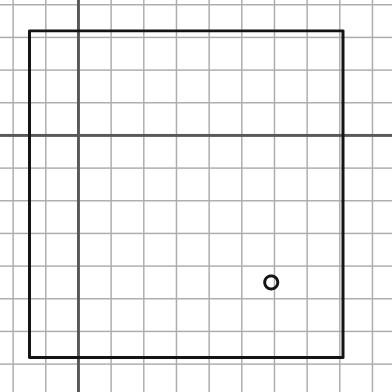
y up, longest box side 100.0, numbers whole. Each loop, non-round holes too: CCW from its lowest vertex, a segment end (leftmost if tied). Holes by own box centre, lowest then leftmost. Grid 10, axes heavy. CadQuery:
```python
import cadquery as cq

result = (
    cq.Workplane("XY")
    .moveTo(-15.0, -68.0)
    .lineTo(81.0, -68.0)
    .lineTo(81.0, 32.0)
    .lineTo(-15.0, 32.0)
    .close()
    .moveTo(59.0, -45.0)
    .circle(2.0)
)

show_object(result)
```